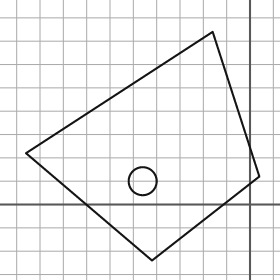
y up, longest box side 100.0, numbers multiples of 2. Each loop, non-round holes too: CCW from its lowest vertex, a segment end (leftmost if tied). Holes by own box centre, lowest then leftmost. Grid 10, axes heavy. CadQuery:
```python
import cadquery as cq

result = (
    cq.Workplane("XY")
    .moveTo(-42.0, -24.0)
    .lineTo(4.0, 12.0)
    .lineTo(-16.0, 74.0)
    .lineTo(-96.0, 22.0)
    .close()
    .moveTo(-46.0, 10.0)
    .circle(6.0)
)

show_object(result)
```